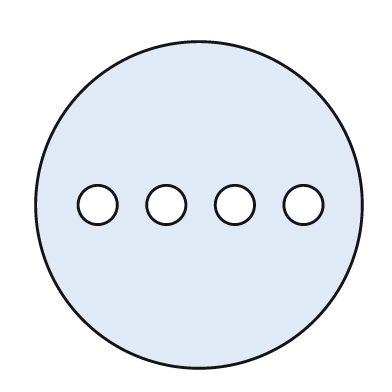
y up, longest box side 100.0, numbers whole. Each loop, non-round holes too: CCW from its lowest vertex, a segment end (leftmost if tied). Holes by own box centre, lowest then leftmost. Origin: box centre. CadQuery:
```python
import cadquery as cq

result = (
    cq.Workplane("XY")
    .moveTo(0.0, 0.0)
    .circle(50.0)
    .moveTo(-31.0, 0.0)
    .circle(6.0)
    .moveTo(-10.0, 0.0)
    .circle(6.0)
    .moveTo(11.0, 0.0)
    .circle(6.0)
    .moveTo(32.0, 0.0)
    .circle(6.0)
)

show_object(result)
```